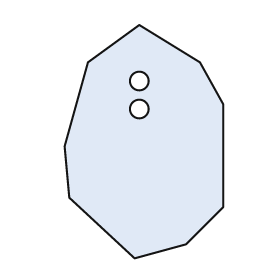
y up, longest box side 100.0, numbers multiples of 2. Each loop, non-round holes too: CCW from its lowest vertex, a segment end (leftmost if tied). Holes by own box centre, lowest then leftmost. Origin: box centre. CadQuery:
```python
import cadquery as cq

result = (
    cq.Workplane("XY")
    .moveTo(-4.0, -50.0)
    .lineTo(18.0, -44.0)
    .lineTo(34.0, -28.0)
    .lineTo(34.0, 16.0)
    .lineTo(24.0, 34.0)
    .lineTo(-2.0, 50.0)
    .lineTo(-24.0, 34.0)
    .lineTo(-34.0, -2.0)
    .lineTo(-32.0, -24.0)
    .close()
    .moveTo(-2.0, 14.0)
    .circle(4.0)
    .moveTo(-2.0, 26.0)
    .circle(4.0)
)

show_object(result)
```